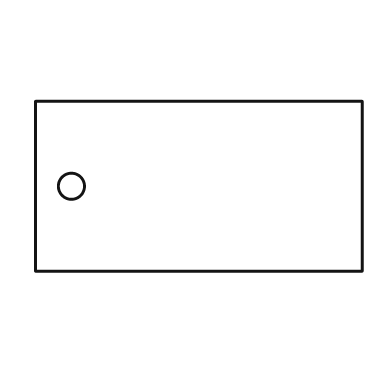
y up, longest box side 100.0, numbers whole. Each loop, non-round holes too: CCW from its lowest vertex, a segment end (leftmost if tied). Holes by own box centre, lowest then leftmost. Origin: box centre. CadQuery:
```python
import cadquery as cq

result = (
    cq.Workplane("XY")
    .moveTo(-50.0, -26.0)
    .lineTo(50.0, -26.0)
    .lineTo(50.0, 26.0)
    .lineTo(-50.0, 26.0)
    .close()
    .moveTo(-39.0, 0.0)
    .circle(4.0)
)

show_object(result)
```